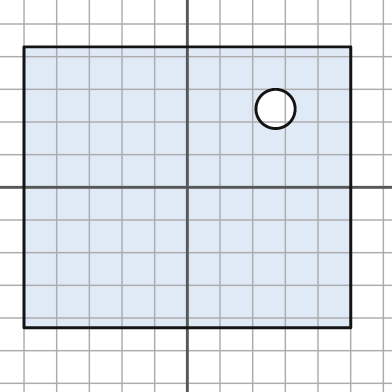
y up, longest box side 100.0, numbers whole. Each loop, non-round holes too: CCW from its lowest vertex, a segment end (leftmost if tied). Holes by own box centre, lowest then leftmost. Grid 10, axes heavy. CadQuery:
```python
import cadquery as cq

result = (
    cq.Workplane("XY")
    .moveTo(-50.0, -43.0)
    .lineTo(50.0, -43.0)
    .lineTo(50.0, 43.0)
    .lineTo(-50.0, 43.0)
    .close()
    .moveTo(27.0, 24.0)
    .circle(6.0)
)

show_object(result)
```